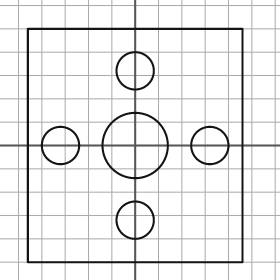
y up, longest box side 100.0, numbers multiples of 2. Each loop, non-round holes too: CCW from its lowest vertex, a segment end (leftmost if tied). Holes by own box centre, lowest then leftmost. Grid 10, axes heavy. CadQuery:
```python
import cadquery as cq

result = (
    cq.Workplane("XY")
    .moveTo(-46.0, -50.0)
    .lineTo(46.0, -50.0)
    .lineTo(46.0, 50.0)
    .lineTo(-46.0, 50.0)
    .close()
    .moveTo(0.0, -32.0)
    .circle(8.0)
    .moveTo(-32.0, 0.0)
    .circle(8.0)
    .moveTo(0.0, 0.0)
    .circle(14.0)
    .moveTo(32.0, 0.0)
    .circle(8.0)
    .moveTo(0.0, 32.0)
    .circle(8.0)
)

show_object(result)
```